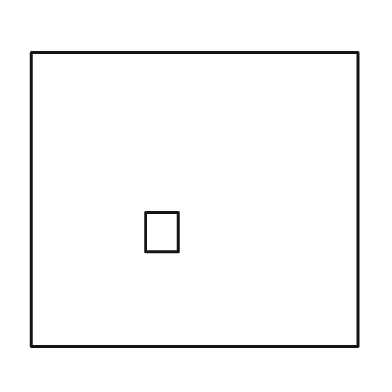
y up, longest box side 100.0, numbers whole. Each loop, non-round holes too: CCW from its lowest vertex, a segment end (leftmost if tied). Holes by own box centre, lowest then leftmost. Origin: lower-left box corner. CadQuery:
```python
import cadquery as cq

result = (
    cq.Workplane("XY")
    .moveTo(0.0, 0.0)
    .lineTo(100.0, 0.0)
    .lineTo(100.0, 90.0)
    .lineTo(0.0, 90.0)
    .close()
    .moveTo(35.0, 29.0)
    .lineTo(45.0, 29.0)
    .lineTo(45.0, 41.0)
    .lineTo(35.0, 41.0)
    .close()
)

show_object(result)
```